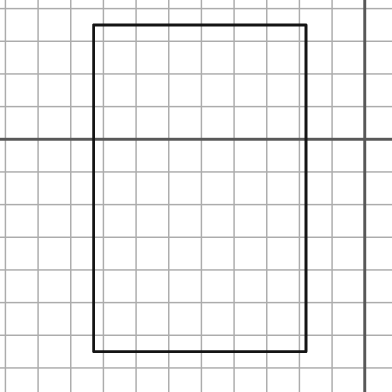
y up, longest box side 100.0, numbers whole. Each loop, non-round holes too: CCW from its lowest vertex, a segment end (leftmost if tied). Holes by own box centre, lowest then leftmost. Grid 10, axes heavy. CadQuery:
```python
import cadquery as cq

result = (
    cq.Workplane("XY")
    .moveTo(-83.0, -65.0)
    .lineTo(-18.0, -65.0)
    .lineTo(-18.0, 35.0)
    .lineTo(-83.0, 35.0)
    .close()
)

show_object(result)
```